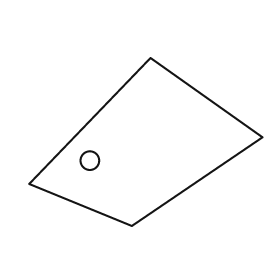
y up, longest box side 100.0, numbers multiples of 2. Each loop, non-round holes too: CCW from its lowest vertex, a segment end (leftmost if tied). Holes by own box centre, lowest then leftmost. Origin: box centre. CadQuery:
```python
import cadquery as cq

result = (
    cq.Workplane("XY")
    .moveTo(-6.0, -36.0)
    .lineTo(50.0, 2.0)
    .lineTo(2.0, 36.0)
    .lineTo(-50.0, -18.0)
    .close()
    .moveTo(-24.0, -8.0)
    .circle(4.0)
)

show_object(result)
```